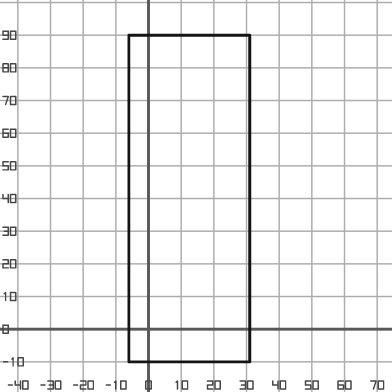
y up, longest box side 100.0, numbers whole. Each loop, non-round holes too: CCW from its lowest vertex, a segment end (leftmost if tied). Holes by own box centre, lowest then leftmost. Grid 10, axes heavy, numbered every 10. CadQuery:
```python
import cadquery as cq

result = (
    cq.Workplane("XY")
    .moveTo(-6.0, -10.0)
    .lineTo(31.0, -10.0)
    .lineTo(31.0, 90.0)
    .lineTo(-6.0, 90.0)
    .close()
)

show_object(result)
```